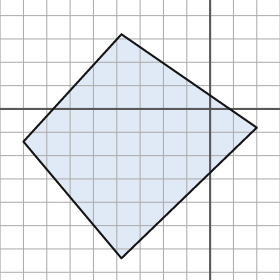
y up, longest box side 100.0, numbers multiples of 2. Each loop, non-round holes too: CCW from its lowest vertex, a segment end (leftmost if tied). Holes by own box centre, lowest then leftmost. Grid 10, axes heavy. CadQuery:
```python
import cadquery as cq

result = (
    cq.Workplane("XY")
    .moveTo(-38.0, -64.0)
    .lineTo(20.0, -8.0)
    .lineTo(-38.0, 32.0)
    .lineTo(-80.0, -14.0)
    .close()
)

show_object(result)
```